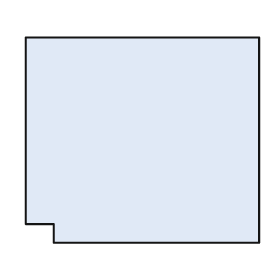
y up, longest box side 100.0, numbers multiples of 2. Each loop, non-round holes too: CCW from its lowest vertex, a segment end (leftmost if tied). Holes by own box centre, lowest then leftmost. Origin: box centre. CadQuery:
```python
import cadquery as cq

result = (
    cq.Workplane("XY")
    .moveTo(-38.0, -44.0)
    .lineTo(50.0, -44.0)
    .lineTo(50.0, 44.0)
    .lineTo(-50.0, 44.0)
    .lineTo(-50.0, -36.0)
    .lineTo(-38.0, -36.0)
    .close()
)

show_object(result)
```